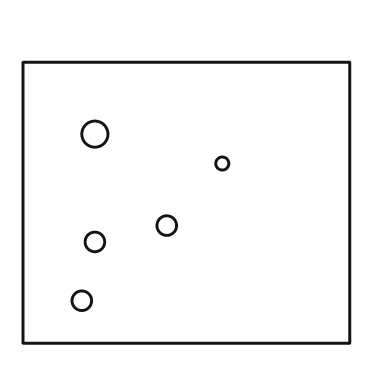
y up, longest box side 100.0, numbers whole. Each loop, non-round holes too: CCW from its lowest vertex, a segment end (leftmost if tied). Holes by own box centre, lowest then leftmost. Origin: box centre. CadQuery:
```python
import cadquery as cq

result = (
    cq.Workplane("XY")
    .moveTo(-50.0, -43.0)
    .lineTo(50.0, -43.0)
    .lineTo(50.0, 43.0)
    .lineTo(-50.0, 43.0)
    .close()
    .moveTo(-32.0, -30.0)
    .circle(3.0)
    .moveTo(-28.0, -12.0)
    .circle(3.0)
    .moveTo(-6.0, -7.0)
    .circle(3.0)
    .moveTo(11.0, 12.0)
    .circle(2.0)
    .moveTo(-28.0, 21.0)
    .circle(4.0)
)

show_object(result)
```